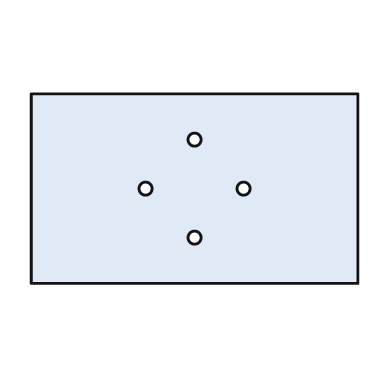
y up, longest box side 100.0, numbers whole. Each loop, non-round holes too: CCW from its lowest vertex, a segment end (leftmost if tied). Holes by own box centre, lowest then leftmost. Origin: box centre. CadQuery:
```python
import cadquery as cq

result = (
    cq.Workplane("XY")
    .moveTo(-50.0, -29.0)
    .lineTo(50.0, -29.0)
    .lineTo(50.0, 29.0)
    .lineTo(-50.0, 29.0)
    .close()
    .moveTo(0.0, -15.0)
    .circle(2.0)
    .moveTo(-15.0, 0.0)
    .circle(2.0)
    .moveTo(15.0, 0.0)
    .circle(2.0)
    .moveTo(0.0, 15.0)
    .circle(2.0)
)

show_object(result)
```